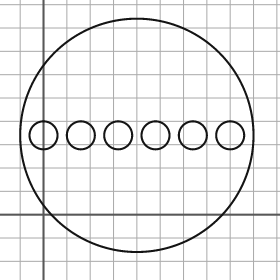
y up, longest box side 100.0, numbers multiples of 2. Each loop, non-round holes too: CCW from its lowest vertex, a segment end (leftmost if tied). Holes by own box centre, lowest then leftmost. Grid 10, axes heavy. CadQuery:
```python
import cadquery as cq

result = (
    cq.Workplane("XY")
    .moveTo(40.0, 34.0)
    .circle(50.0)
    .moveTo(0.0, 34.0)
    .circle(6.0)
    .moveTo(16.0, 34.0)
    .circle(6.0)
    .moveTo(32.0, 34.0)
    .circle(6.0)
    .moveTo(48.0, 34.0)
    .circle(6.0)
    .moveTo(64.0, 34.0)
    .circle(6.0)
    .moveTo(80.0, 34.0)
    .circle(6.0)
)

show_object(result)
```